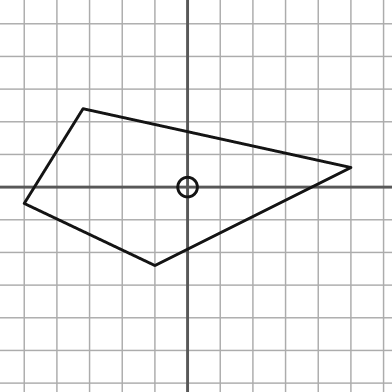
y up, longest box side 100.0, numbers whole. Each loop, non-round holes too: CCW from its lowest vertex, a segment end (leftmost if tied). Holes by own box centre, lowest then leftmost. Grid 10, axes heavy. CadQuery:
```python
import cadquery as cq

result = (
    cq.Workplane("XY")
    .moveTo(-10.0, -24.0)
    .lineTo(50.0, 6.0)
    .lineTo(-32.0, 24.0)
    .lineTo(-50.0, -5.0)
    .close()
    .moveTo(0.0, 0.0)
    .circle(3.0)
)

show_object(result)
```